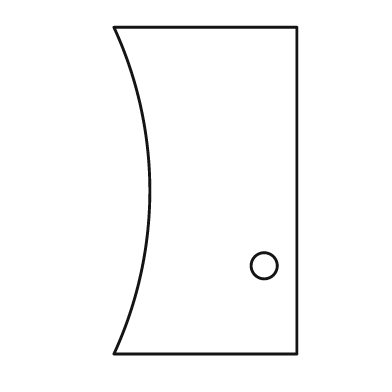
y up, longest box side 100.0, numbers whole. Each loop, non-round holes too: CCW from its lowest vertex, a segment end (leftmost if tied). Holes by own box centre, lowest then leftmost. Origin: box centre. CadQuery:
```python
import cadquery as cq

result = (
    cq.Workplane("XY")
    .moveTo(-28.0, -50.0)
    .lineTo(28.0, -50.0)
    .lineTo(28.0, 50.0)
    .lineTo(-28.0, 50.0)
    .threePointArc((-17.0, 0.0), (-28.0, -50.0))
    .close()
    .moveTo(18.0, -23.0)
    .circle(4.0)
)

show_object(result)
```